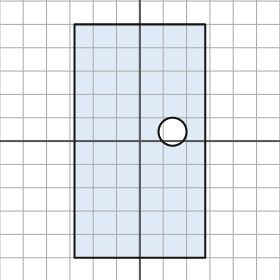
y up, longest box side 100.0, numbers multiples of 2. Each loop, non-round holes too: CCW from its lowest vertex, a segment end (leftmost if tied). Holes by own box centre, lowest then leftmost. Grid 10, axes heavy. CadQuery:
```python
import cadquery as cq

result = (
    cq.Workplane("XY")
    .moveTo(-28.0, -50.0)
    .lineTo(28.0, -50.0)
    .lineTo(28.0, 50.0)
    .lineTo(-28.0, 50.0)
    .close()
    .moveTo(14.0, 4.0)
    .circle(6.0)
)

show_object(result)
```